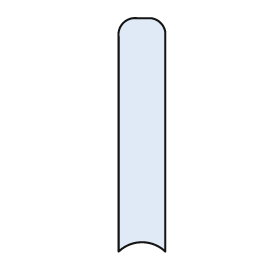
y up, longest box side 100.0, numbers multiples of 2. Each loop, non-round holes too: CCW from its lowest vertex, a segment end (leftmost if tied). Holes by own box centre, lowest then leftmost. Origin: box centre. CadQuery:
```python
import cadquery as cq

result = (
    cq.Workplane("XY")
    .moveTo(-10.0, -50.0)
    .threePointArc((0.0, -46.0), (10.0, -50.0))
    .lineTo(10.0, 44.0)
    .threePointArc((8.0, 48.0), (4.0, 50.0))
    .lineTo(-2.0, 50.0)
    .threePointArc((-8.0, 48.0), (-10.0, 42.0))
    .close()
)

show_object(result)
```